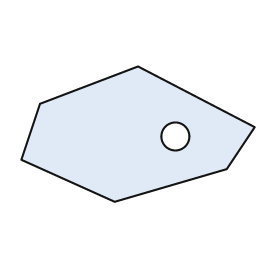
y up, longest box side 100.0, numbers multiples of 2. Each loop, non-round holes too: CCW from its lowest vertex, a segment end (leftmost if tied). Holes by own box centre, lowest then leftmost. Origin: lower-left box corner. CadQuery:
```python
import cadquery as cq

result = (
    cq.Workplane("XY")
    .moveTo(40.0, 0.0)
    .lineTo(88.0, 14.0)
    .lineTo(100.0, 32.0)
    .lineTo(50.0, 58.0)
    .lineTo(8.0, 42.0)
    .lineTo(0.0, 18.0)
    .close()
    .moveTo(66.0, 28.0)
    .circle(6.0)
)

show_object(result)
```